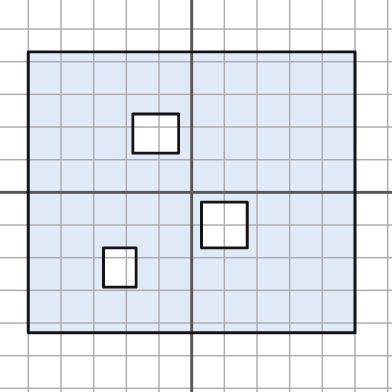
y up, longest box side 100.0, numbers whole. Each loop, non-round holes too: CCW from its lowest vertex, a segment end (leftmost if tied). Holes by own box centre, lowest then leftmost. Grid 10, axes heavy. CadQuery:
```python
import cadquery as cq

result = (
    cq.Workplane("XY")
    .moveTo(-50.0, -43.0)
    .lineTo(50.0, -43.0)
    .lineTo(50.0, 43.0)
    .lineTo(-50.0, 43.0)
    .close()
    .moveTo(-27.0, -29.0)
    .lineTo(-17.0, -29.0)
    .lineTo(-17.0, -17.0)
    .lineTo(-27.0, -17.0)
    .close()
    .moveTo(3.0, -17.0)
    .lineTo(17.0, -17.0)
    .lineTo(17.0, -3.0)
    .lineTo(3.0, -3.0)
    .close()
    .moveTo(-18.0, 12.0)
    .lineTo(-4.0, 12.0)
    .lineTo(-4.0, 24.0)
    .lineTo(-18.0, 24.0)
    .close()
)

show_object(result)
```